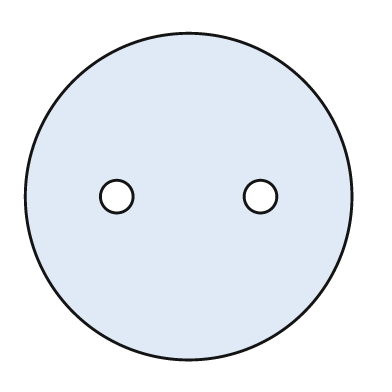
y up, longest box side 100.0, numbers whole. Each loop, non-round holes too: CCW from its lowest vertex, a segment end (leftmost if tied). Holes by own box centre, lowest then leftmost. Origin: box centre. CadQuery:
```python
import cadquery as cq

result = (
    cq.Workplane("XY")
    .moveTo(0.0, 0.0)
    .circle(50.0)
    .moveTo(-22.0, 0.0)
    .circle(5.0)
    .moveTo(22.0, 0.0)
    .circle(5.0)
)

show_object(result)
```